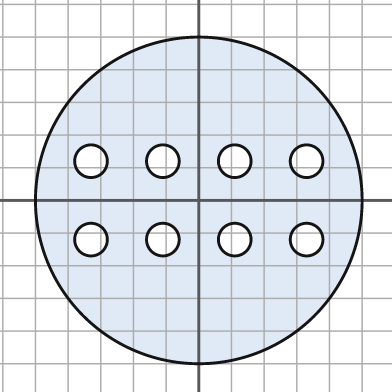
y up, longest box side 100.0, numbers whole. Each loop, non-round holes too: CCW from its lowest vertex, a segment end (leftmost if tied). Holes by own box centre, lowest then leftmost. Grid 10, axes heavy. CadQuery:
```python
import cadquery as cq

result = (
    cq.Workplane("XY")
    .moveTo(0.0, 0.0)
    .circle(50.0)
    .moveTo(-33.0, -12.0)
    .circle(5.0)
    .moveTo(-11.0, -12.0)
    .circle(5.0)
    .moveTo(11.0, -12.0)
    .circle(5.0)
    .moveTo(33.0, -12.0)
    .circle(5.0)
    .moveTo(-33.0, 12.0)
    .circle(5.0)
    .moveTo(-11.0, 12.0)
    .circle(5.0)
    .moveTo(11.0, 12.0)
    .circle(5.0)
    .moveTo(33.0, 12.0)
    .circle(5.0)
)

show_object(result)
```